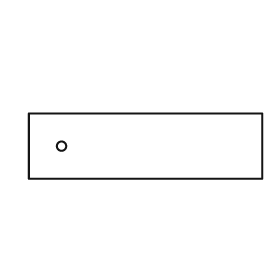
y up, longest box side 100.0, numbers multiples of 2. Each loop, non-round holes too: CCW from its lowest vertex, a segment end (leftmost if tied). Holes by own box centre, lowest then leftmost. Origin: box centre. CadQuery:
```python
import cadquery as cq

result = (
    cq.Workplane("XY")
    .moveTo(-50.0, -14.0)
    .lineTo(50.0, -14.0)
    .lineTo(50.0, 14.0)
    .lineTo(-50.0, 14.0)
    .close()
    .moveTo(-36.0, 0.0)
    .circle(2.0)
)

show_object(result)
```